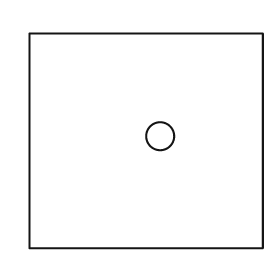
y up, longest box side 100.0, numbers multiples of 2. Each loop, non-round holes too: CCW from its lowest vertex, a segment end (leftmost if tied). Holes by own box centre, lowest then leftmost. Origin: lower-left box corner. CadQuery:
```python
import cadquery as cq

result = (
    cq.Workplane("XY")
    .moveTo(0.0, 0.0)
    .lineTo(100.0, 0.0)
    .lineTo(100.0, 92.0)
    .lineTo(0.0, 92.0)
    .close()
    .moveTo(56.0, 48.0)
    .circle(6.0)
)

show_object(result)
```